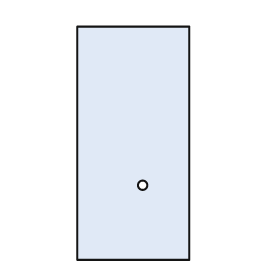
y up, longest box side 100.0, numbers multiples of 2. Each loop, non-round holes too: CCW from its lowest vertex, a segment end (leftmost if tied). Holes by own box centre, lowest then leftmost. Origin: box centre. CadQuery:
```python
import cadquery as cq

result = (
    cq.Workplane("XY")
    .moveTo(-24.0, -50.0)
    .lineTo(24.0, -50.0)
    .lineTo(24.0, 50.0)
    .lineTo(-24.0, 50.0)
    .close()
    .moveTo(4.0, -18.0)
    .circle(2.0)
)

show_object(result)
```